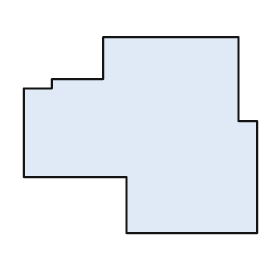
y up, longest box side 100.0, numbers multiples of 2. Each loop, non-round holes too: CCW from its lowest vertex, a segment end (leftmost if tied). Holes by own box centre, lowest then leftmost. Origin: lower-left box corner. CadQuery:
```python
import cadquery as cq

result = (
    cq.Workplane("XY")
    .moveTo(44.0, 0.0)
    .lineTo(100.0, 0.0)
    .lineTo(100.0, 48.0)
    .lineTo(92.0, 48.0)
    .lineTo(92.0, 84.0)
    .lineTo(34.0, 84.0)
    .lineTo(34.0, 66.0)
    .lineTo(12.0, 66.0)
    .lineTo(12.0, 62.0)
    .lineTo(0.0, 62.0)
    .lineTo(0.0, 24.0)
    .lineTo(44.0, 24.0)
    .close()
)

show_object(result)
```